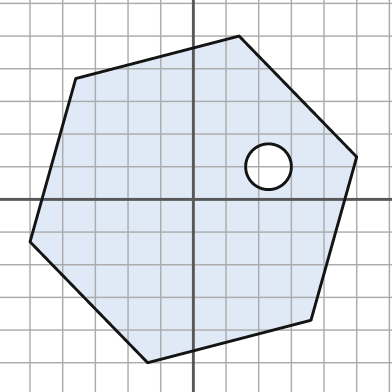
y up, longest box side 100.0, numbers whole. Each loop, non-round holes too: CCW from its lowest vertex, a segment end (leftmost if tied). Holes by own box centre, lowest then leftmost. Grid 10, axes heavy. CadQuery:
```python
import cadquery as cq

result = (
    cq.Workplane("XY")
    .moveTo(-14.0, -50.0)
    .lineTo(36.0, -37.0)
    .lineTo(50.0, 13.0)
    .lineTo(14.0, 50.0)
    .lineTo(-36.0, 37.0)
    .lineTo(-50.0, -13.0)
    .close()
    .moveTo(23.0, 10.0)
    .circle(7.0)
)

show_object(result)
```